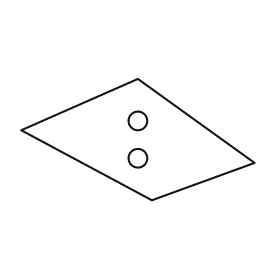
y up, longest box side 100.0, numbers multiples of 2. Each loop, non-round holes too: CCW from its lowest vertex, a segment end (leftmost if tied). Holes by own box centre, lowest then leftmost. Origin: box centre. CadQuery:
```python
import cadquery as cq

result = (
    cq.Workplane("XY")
    .moveTo(6.0, -26.0)
    .lineTo(50.0, -10.0)
    .lineTo(0.0, 26.0)
    .lineTo(-50.0, 4.0)
    .close()
    .moveTo(0.0, -8.0)
    .circle(4.0)
    .moveTo(0.0, 8.0)
    .circle(4.0)
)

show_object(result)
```